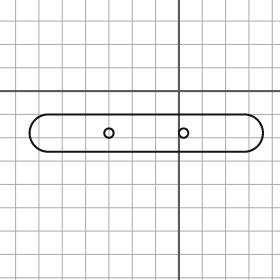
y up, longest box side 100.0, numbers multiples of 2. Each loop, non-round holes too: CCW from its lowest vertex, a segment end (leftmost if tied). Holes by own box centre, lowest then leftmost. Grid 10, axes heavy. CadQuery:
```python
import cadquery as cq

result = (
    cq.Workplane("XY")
    .moveTo(-56.0, -26.0)
    .lineTo(28.0, -26.0)
    .threePointArc((36.0, -18.0), (28.0, -10.0))
    .lineTo(-56.0, -10.0)
    .threePointArc((-64.0, -18.0), (-56.0, -26.0))
    .close()
    .moveTo(-30.0, -18.0)
    .circle(2.0)
    .moveTo(2.0, -18.0)
    .circle(2.0)
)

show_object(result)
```